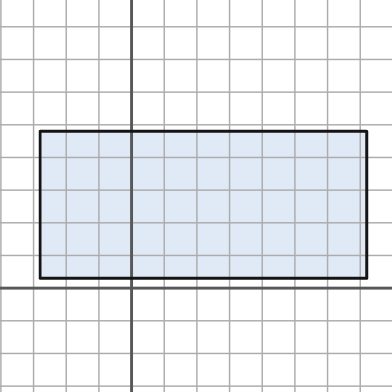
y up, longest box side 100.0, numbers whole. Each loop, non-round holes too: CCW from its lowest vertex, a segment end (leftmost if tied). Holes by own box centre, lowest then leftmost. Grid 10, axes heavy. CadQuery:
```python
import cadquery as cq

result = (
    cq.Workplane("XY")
    .moveTo(-28.0, 3.0)
    .lineTo(72.0, 3.0)
    .lineTo(72.0, 48.0)
    .lineTo(-28.0, 48.0)
    .close()
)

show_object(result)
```